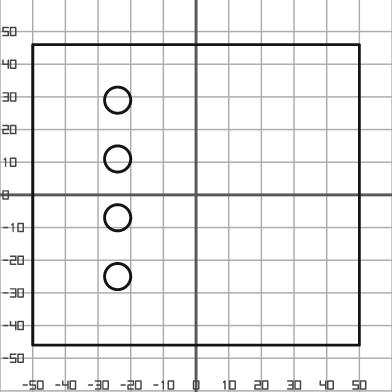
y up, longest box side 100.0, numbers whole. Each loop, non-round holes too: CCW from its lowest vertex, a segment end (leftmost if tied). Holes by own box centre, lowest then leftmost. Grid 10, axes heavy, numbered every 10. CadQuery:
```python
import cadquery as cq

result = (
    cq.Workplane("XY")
    .moveTo(-50.0, -46.0)
    .lineTo(50.0, -46.0)
    .lineTo(50.0, 46.0)
    .lineTo(-50.0, 46.0)
    .close()
    .moveTo(-24.0, -25.0)
    .circle(4.0)
    .moveTo(-24.0, -7.0)
    .circle(4.0)
    .moveTo(-24.0, 11.0)
    .circle(4.0)
    .moveTo(-24.0, 29.0)
    .circle(4.0)
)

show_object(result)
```